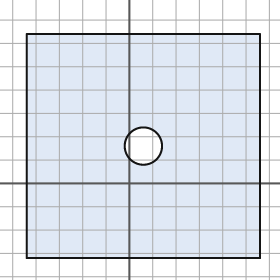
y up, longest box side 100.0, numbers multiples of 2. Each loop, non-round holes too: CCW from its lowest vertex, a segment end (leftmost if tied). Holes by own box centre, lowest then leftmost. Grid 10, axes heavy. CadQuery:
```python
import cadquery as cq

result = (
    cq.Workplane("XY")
    .moveTo(-44.0, -32.0)
    .lineTo(56.0, -32.0)
    .lineTo(56.0, 64.0)
    .lineTo(-44.0, 64.0)
    .close()
    .moveTo(6.0, 16.0)
    .circle(8.0)
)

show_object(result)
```